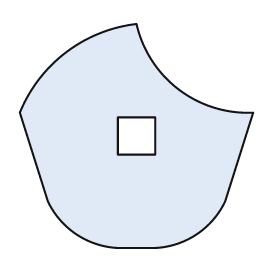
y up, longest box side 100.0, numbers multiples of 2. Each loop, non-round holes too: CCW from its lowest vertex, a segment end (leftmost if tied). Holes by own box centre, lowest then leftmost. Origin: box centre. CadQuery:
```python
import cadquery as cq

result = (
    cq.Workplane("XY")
    .moveTo(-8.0, -48.0)
    .lineTo(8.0, -48.0)
    .threePointArc((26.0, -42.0), (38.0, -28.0))
    .lineTo(50.0, 10.0)
    .threePointArc((18.0, 20.0), (0.0, 48.0))
    .threePointArc((-30.0, 36.0), (-50.0, 10.0))
    .lineTo(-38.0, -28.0)
    .threePointArc((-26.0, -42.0), (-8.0, -48.0))
    .close()
    .moveTo(-8.0, -8.0)
    .lineTo(8.0, -8.0)
    .lineTo(8.0, 8.0)
    .lineTo(-8.0, 8.0)
    .close()
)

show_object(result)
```